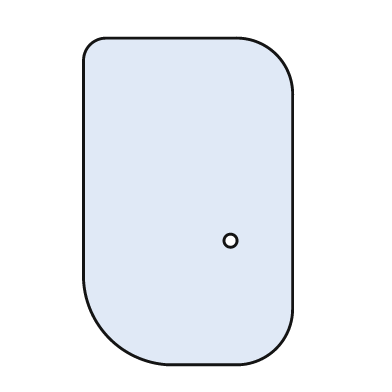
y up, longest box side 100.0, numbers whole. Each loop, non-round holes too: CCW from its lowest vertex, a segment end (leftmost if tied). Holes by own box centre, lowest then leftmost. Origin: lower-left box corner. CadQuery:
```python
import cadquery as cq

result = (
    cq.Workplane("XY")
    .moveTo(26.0, 0.0)
    .lineTo(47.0, 0.0)
    .threePointArc((59.0, 5.0), (64.0, 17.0))
    .lineTo(64.0, 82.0)
    .threePointArc((59.0, 95.0), (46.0, 100.0))
    .lineTo(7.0, 100.0)
    .threePointArc((2.0, 98.0), (0.0, 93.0))
    .lineTo(0.0, 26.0)
    .threePointArc((8.0, 8.0), (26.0, 0.0))
    .close()
    .moveTo(45.0, 38.0)
    .circle(2.0)
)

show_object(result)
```